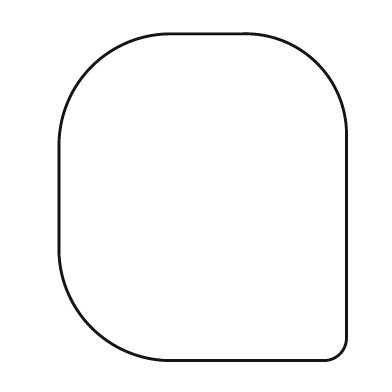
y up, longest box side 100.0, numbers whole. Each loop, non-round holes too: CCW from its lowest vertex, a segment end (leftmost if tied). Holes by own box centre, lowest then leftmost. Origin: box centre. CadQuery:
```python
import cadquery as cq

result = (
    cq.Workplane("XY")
    .moveTo(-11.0, -50.0)
    .lineTo(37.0, -50.0)
    .threePointArc((42.0, -48.0), (44.0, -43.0))
    .lineTo(44.0, 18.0)
    .threePointArc((35.0, 41.0), (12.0, 50.0))
    .lineTo(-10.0, 50.0)
    .threePointArc((-34.0, 40.0), (-44.0, 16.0))
    .lineTo(-44.0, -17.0)
    .threePointArc((-34.0, -40.0), (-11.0, -50.0))
    .close()
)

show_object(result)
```